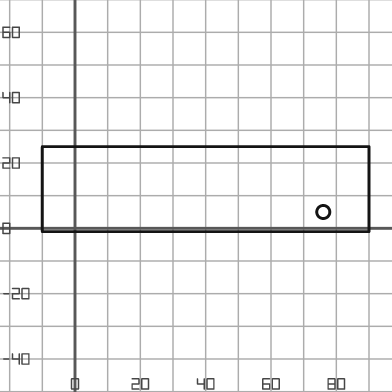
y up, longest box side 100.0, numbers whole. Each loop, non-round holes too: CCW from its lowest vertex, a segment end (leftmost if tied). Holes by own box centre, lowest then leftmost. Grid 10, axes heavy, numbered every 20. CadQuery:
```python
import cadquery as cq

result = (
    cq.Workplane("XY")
    .moveTo(-10.0, -1.0)
    .lineTo(90.0, -1.0)
    .lineTo(90.0, 25.0)
    .lineTo(-10.0, 25.0)
    .close()
    .moveTo(76.0, 5.0)
    .circle(2.0)
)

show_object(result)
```